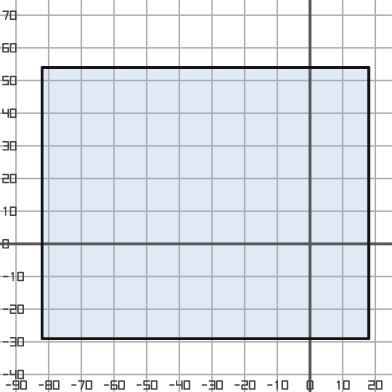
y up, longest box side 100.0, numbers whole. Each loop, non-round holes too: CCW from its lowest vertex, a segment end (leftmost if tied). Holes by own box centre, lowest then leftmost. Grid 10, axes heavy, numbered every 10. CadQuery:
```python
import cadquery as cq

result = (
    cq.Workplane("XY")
    .moveTo(-82.0, -29.0)
    .lineTo(18.0, -29.0)
    .lineTo(18.0, 54.0)
    .lineTo(-82.0, 54.0)
    .close()
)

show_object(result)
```